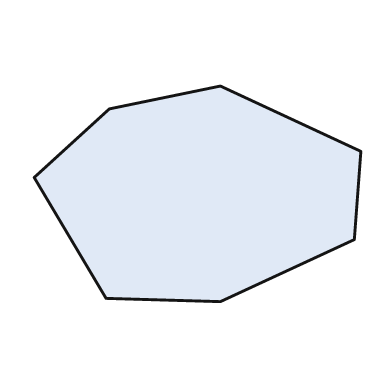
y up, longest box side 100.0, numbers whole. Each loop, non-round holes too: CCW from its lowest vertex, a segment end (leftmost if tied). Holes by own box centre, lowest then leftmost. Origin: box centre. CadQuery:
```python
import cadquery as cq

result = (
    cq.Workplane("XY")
    .moveTo(7.0, -33.0)
    .lineTo(48.0, -14.0)
    .lineTo(50.0, 13.0)
    .lineTo(7.0, 33.0)
    .lineTo(-27.0, 26.0)
    .lineTo(-50.0, 5.0)
    .lineTo(-28.0, -32.0)
    .close()
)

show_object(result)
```